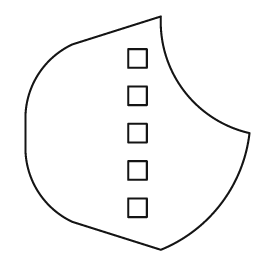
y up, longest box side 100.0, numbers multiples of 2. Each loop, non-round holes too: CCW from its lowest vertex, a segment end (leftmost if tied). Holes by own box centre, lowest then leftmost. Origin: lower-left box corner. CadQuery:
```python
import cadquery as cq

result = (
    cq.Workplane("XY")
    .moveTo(58.0, 0.0)
    .threePointArc((84.0, 20.0), (96.0, 50.0))
    .threePointArc((68.0, 68.0), (58.0, 100.0))
    .lineTo(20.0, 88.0)
    .threePointArc((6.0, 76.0), (0.0, 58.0))
    .lineTo(0.0, 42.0)
    .threePointArc((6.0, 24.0), (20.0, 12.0))
    .close()
    .moveTo(44.0, 14.0)
    .lineTo(52.0, 14.0)
    .lineTo(52.0, 22.0)
    .lineTo(44.0, 22.0)
    .close()
    .moveTo(44.0, 30.0)
    .lineTo(52.0, 30.0)
    .lineTo(52.0, 38.0)
    .lineTo(44.0, 38.0)
    .close()
    .moveTo(44.0, 46.0)
    .lineTo(52.0, 46.0)
    .lineTo(52.0, 54.0)
    .lineTo(44.0, 54.0)
    .close()
    .moveTo(44.0, 62.0)
    .lineTo(52.0, 62.0)
    .lineTo(52.0, 70.0)
    .lineTo(44.0, 70.0)
    .close()
    .moveTo(44.0, 78.0)
    .lineTo(52.0, 78.0)
    .lineTo(52.0, 86.0)
    .lineTo(44.0, 86.0)
    .close()
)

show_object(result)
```